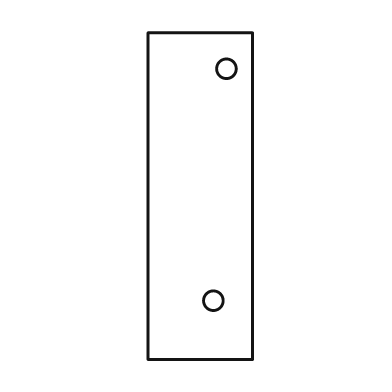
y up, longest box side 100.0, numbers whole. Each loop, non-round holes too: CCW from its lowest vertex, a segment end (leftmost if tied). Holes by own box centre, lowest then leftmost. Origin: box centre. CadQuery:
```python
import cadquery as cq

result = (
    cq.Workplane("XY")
    .moveTo(-16.0, -50.0)
    .lineTo(16.0, -50.0)
    .lineTo(16.0, 50.0)
    .lineTo(-16.0, 50.0)
    .close()
    .moveTo(4.0, -32.0)
    .circle(3.0)
    .moveTo(8.0, 39.0)
    .circle(3.0)
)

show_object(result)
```